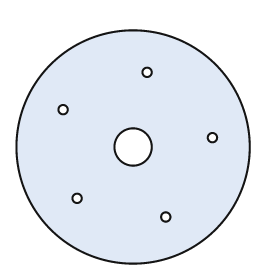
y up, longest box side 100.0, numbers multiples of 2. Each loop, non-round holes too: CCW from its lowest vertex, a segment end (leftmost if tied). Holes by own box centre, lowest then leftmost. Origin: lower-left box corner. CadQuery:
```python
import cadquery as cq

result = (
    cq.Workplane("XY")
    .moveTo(50.0, 50.0)
    .circle(50.0)
    .moveTo(64.0, 20.0)
    .circle(2.0)
    .moveTo(26.0, 28.0)
    .circle(2.0)
    .moveTo(50.0, 50.0)
    .circle(8.0)
    .moveTo(84.0, 54.0)
    .circle(2.0)
    .moveTo(20.0, 66.0)
    .circle(2.0)
    .moveTo(56.0, 82.0)
    .circle(2.0)
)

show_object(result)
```